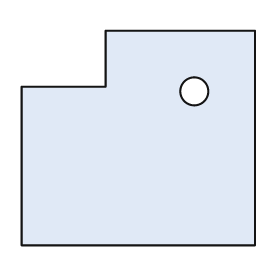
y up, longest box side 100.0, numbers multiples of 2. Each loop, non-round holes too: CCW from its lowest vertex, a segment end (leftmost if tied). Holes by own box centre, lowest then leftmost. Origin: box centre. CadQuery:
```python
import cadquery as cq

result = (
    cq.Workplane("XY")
    .moveTo(-50.0, -46.0)
    .lineTo(50.0, -46.0)
    .lineTo(50.0, 46.0)
    .lineTo(-14.0, 46.0)
    .lineTo(-14.0, 22.0)
    .lineTo(-50.0, 22.0)
    .close()
    .moveTo(24.0, 20.0)
    .circle(6.0)
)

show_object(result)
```